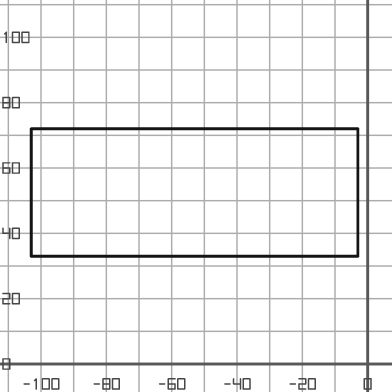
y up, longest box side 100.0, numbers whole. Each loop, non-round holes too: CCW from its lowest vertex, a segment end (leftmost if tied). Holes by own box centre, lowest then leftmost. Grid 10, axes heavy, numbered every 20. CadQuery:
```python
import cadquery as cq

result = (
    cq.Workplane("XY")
    .moveTo(-103.0, 33.0)
    .lineTo(-3.0, 33.0)
    .lineTo(-3.0, 72.0)
    .lineTo(-103.0, 72.0)
    .close()
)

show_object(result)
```